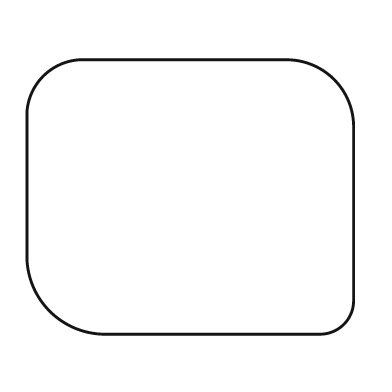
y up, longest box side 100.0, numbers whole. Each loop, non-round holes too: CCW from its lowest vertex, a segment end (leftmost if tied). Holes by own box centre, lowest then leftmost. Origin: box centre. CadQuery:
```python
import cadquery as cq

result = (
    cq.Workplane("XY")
    .moveTo(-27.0, -42.0)
    .lineTo(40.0, -42.0)
    .threePointArc((47.0, -39.0), (50.0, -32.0))
    .lineTo(50.0, 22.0)
    .threePointArc((44.0, 36.0), (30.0, 42.0))
    .lineTo(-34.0, 42.0)
    .threePointArc((-45.0, 37.0), (-50.0, 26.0))
    .lineTo(-50.0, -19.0)
    .threePointArc((-43.0, -35.0), (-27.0, -42.0))
    .close()
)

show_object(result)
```